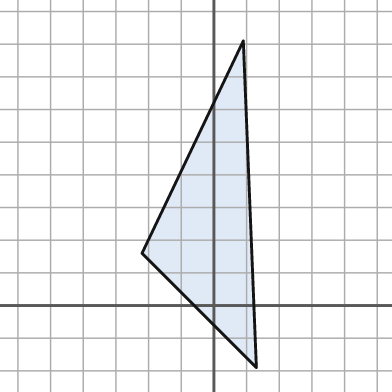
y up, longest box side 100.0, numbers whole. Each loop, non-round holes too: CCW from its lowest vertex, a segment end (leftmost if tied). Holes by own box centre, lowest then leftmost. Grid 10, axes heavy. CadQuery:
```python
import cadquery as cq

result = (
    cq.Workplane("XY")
    .moveTo(13.0, -19.0)
    .lineTo(9.0, 81.0)
    .lineTo(-22.0, 16.0)
    .close()
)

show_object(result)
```